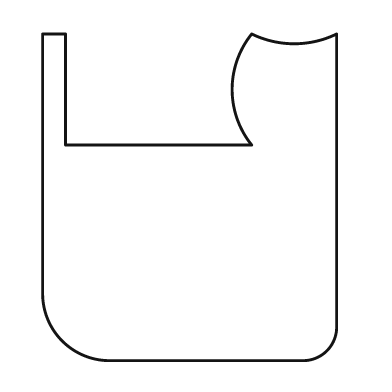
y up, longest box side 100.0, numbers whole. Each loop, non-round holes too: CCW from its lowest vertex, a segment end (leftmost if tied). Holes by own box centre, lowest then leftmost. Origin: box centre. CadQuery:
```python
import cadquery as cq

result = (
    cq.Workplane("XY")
    .moveTo(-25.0, -50.0)
    .lineTo(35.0, -50.0)
    .threePointArc((42.0, -47.0), (45.0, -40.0))
    .lineTo(45.0, 50.0)
    .threePointArc((32.0, 47.0), (19.0, 50.0))
    .threePointArc((13.0, 33.0), (19.0, 16.0))
    .lineTo(-38.0, 16.0)
    .lineTo(-38.0, 50.0)
    .lineTo(-45.0, 50.0)
    .lineTo(-45.0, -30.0)
    .threePointArc((-39.0, -44.0), (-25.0, -50.0))
    .close()
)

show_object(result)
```